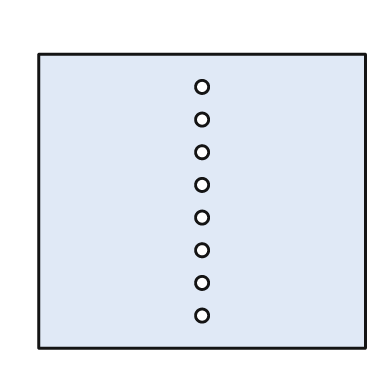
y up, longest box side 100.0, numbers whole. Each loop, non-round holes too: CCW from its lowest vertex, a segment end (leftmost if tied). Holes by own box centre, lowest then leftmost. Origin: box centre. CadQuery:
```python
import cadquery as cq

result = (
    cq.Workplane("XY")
    .moveTo(-50.0, -45.0)
    .lineTo(50.0, -45.0)
    .lineTo(50.0, 45.0)
    .lineTo(-50.0, 45.0)
    .close()
    .moveTo(0.0, -35.0)
    .circle(2.0)
    .moveTo(0.0, -25.0)
    .circle(2.0)
    .moveTo(0.0, -15.0)
    .circle(2.0)
    .moveTo(0.0, -5.0)
    .circle(2.0)
    .moveTo(0.0, 5.0)
    .circle(2.0)
    .moveTo(0.0, 15.0)
    .circle(2.0)
    .moveTo(0.0, 25.0)
    .circle(2.0)
    .moveTo(0.0, 35.0)
    .circle(2.0)
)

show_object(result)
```